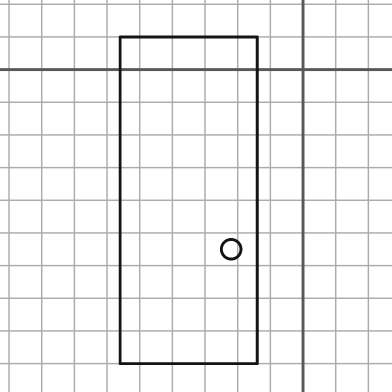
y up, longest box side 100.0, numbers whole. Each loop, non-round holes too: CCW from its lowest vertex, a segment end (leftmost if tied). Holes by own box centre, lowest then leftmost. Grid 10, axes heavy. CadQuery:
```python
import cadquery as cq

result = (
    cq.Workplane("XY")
    .moveTo(-56.0, -90.0)
    .lineTo(-14.0, -90.0)
    .lineTo(-14.0, 10.0)
    .lineTo(-56.0, 10.0)
    .close()
    .moveTo(-22.0, -55.0)
    .circle(3.0)
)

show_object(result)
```